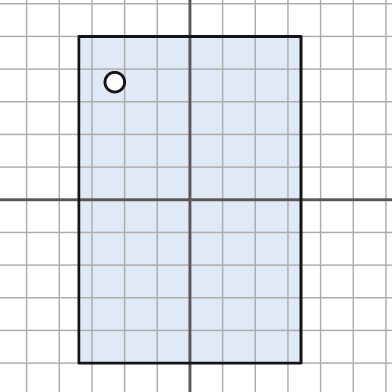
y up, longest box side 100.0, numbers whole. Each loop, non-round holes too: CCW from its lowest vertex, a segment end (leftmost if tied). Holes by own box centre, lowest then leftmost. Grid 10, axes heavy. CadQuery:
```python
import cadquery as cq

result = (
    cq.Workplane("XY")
    .moveTo(-34.0, -50.0)
    .lineTo(34.0, -50.0)
    .lineTo(34.0, 50.0)
    .lineTo(-34.0, 50.0)
    .close()
    .moveTo(-23.0, 36.0)
    .circle(3.0)
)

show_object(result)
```